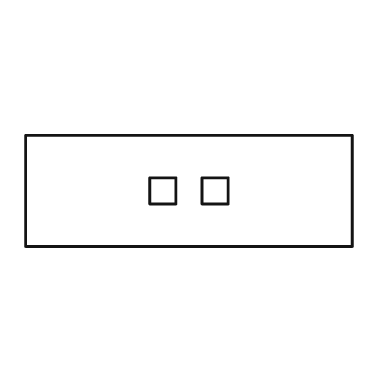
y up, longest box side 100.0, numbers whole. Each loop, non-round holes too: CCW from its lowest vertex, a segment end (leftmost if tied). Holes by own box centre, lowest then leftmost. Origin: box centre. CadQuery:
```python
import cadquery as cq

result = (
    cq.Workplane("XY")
    .moveTo(-50.0, -17.0)
    .lineTo(50.0, -17.0)
    .lineTo(50.0, 17.0)
    .lineTo(-50.0, 17.0)
    .close()
    .moveTo(-12.0, -4.0)
    .lineTo(-4.0, -4.0)
    .lineTo(-4.0, 4.0)
    .lineTo(-12.0, 4.0)
    .close()
    .moveTo(4.0, -4.0)
    .lineTo(12.0, -4.0)
    .lineTo(12.0, 4.0)
    .lineTo(4.0, 4.0)
    .close()
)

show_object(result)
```